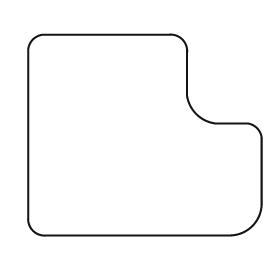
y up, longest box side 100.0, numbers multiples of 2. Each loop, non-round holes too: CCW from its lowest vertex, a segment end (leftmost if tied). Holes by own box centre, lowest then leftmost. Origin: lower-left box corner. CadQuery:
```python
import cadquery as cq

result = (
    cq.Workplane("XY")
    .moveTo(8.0, 0.0)
    .lineTo(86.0, 0.0)
    .threePointArc((96.0, 4.0), (100.0, 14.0))
    .lineTo(100.0, 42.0)
    .threePointArc((98.0, 46.0), (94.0, 48.0))
    .lineTo(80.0, 48.0)
    .threePointArc((72.0, 52.0), (68.0, 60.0))
    .lineTo(68.0, 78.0)
    .threePointArc((66.0, 84.0), (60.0, 86.0))
    .lineTo(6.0, 86.0)
    .threePointArc((2.0, 84.0), (0.0, 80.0))
    .lineTo(0.0, 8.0)
    .threePointArc((2.0, 2.0), (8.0, 0.0))
    .close()
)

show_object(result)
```